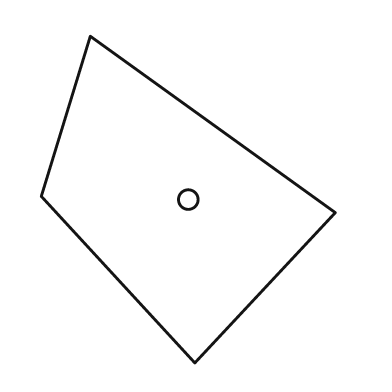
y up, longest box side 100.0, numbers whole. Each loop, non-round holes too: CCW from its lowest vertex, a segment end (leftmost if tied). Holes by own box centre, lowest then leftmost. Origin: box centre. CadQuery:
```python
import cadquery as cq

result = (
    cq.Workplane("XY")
    .moveTo(2.0, -50.0)
    .lineTo(45.0, -4.0)
    .lineTo(-30.0, 50.0)
    .lineTo(-45.0, 1.0)
    .close()
    .moveTo(0.0, 0.0)
    .circle(3.0)
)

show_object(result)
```